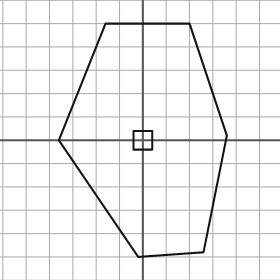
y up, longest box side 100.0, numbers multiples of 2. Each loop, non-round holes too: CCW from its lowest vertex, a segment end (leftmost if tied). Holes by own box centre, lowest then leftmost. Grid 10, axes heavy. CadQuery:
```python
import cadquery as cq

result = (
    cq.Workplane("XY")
    .moveTo(-2.0, -50.0)
    .lineTo(26.0, -48.0)
    .lineTo(36.0, 2.0)
    .lineTo(20.0, 50.0)
    .lineTo(-16.0, 50.0)
    .lineTo(-36.0, 0.0)
    .close()
    .moveTo(-4.0, -4.0)
    .lineTo(4.0, -4.0)
    .lineTo(4.0, 4.0)
    .lineTo(-4.0, 4.0)
    .close()
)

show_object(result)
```